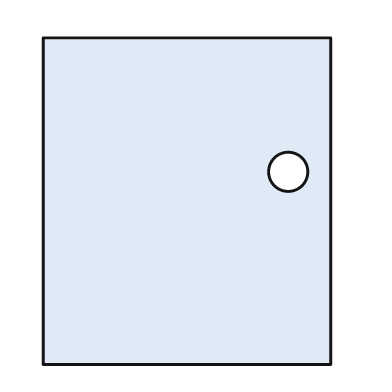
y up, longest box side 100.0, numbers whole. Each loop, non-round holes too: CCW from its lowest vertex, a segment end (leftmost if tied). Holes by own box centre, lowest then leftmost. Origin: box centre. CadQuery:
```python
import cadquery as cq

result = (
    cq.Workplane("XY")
    .moveTo(-44.0, -50.0)
    .lineTo(44.0, -50.0)
    .lineTo(44.0, 50.0)
    .lineTo(-44.0, 50.0)
    .close()
    .moveTo(31.0, 9.0)
    .circle(6.0)
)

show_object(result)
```